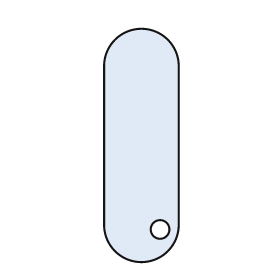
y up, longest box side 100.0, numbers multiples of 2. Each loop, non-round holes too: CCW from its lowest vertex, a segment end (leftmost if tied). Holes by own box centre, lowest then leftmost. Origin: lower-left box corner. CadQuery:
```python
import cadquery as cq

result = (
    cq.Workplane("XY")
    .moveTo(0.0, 16.0)
    .threePointArc((16.0, 0.0), (32.0, 16.0))
    .lineTo(32.0, 84.0)
    .threePointArc((16.0, 100.0), (0.0, 84.0))
    .close()
    .moveTo(24.0, 14.0)
    .circle(4.0)
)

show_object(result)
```